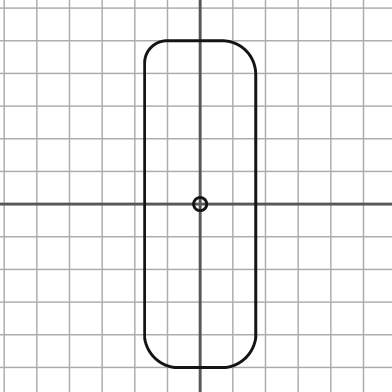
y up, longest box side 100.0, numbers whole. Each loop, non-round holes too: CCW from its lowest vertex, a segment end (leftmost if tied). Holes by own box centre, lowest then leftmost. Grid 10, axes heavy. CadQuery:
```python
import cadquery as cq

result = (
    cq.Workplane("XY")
    .moveTo(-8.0, -50.0)
    .lineTo(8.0, -50.0)
    .threePointArc((14.0, -47.0), (17.0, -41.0))
    .lineTo(17.0, 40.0)
    .threePointArc((14.0, 47.0), (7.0, 50.0))
    .lineTo(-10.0, 50.0)
    .threePointArc((-15.0, 48.0), (-17.0, 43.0))
    .lineTo(-17.0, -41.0)
    .threePointArc((-14.0, -47.0), (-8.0, -50.0))
    .close()
    .moveTo(0.0, 0.0)
    .circle(2.0)
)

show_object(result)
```